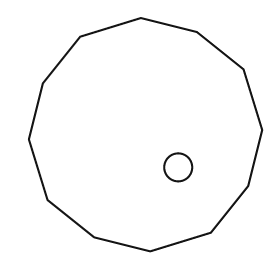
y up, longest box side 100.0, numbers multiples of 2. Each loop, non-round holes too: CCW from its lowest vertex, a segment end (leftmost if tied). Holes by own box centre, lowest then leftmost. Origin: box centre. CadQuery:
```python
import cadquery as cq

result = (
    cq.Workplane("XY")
    .moveTo(2.0, -50.0)
    .lineTo(28.0, -42.0)
    .lineTo(44.0, -22.0)
    .lineTo(50.0, 2.0)
    .lineTo(42.0, 28.0)
    .lineTo(22.0, 44.0)
    .lineTo(-2.0, 50.0)
    .lineTo(-28.0, 42.0)
    .lineTo(-44.0, 22.0)
    .lineTo(-50.0, -2.0)
    .lineTo(-42.0, -28.0)
    .lineTo(-22.0, -44.0)
    .close()
    .moveTo(14.0, -14.0)
    .circle(6.0)
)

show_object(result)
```